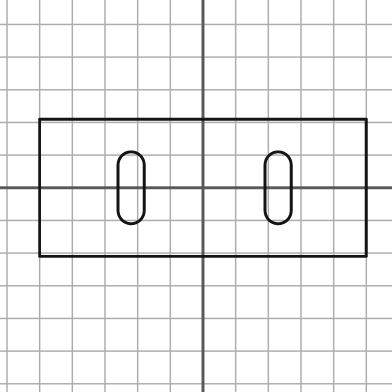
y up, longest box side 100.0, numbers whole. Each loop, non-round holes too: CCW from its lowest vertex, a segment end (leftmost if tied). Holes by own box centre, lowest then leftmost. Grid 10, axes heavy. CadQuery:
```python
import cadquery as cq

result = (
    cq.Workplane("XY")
    .moveTo(-50.0, -21.0)
    .lineTo(50.0, -21.0)
    .lineTo(50.0, 21.0)
    .lineTo(-50.0, 21.0)
    .close()
    .moveTo(-26.0, -7.0)
    .threePointArc((-22.0, -11.0), (-18.0, -7.0))
    .lineTo(-18.0, 7.0)
    .threePointArc((-22.0, 11.0), (-26.0, 7.0))
    .close()
    .moveTo(19.0, -7.0)
    .threePointArc((23.0, -11.0), (27.0, -7.0))
    .lineTo(27.0, 7.0)
    .threePointArc((23.0, 11.0), (19.0, 7.0))
    .close()
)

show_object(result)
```